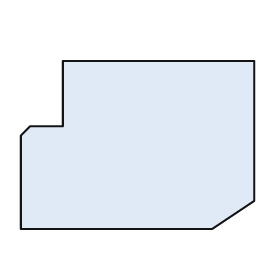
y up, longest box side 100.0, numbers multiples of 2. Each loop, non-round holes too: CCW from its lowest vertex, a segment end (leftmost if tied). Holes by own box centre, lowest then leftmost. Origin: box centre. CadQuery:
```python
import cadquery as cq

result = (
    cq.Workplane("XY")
    .moveTo(-50.0, -36.0)
    .lineTo(32.0, -36.0)
    .lineTo(50.0, -24.0)
    .lineTo(50.0, 36.0)
    .lineTo(-32.0, 36.0)
    .lineTo(-32.0, 8.0)
    .lineTo(-46.0, 8.0)
    .lineTo(-50.0, 4.0)
    .close()
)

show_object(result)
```